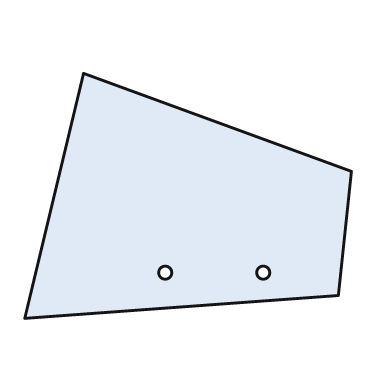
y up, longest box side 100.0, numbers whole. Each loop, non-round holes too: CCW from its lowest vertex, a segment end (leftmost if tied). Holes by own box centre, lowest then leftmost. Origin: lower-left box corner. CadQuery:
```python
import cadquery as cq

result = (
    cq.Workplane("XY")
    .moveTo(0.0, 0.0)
    .lineTo(96.0, 7.0)
    .lineTo(100.0, 45.0)
    .lineTo(18.0, 75.0)
    .close()
    .moveTo(43.0, 14.0)
    .circle(2.0)
    .moveTo(73.0, 14.0)
    .circle(2.0)
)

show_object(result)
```